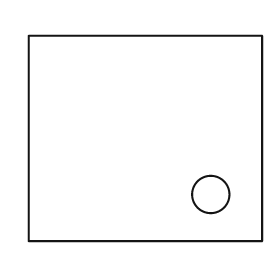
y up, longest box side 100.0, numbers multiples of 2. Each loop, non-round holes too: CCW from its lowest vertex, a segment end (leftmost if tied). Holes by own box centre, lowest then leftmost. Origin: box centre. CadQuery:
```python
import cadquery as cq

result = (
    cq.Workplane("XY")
    .moveTo(-50.0, -44.0)
    .lineTo(50.0, -44.0)
    .lineTo(50.0, 44.0)
    .lineTo(-50.0, 44.0)
    .close()
    .moveTo(28.0, -24.0)
    .circle(8.0)
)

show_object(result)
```